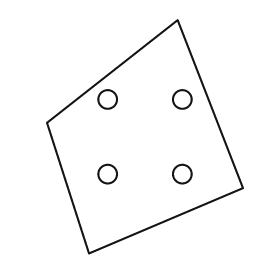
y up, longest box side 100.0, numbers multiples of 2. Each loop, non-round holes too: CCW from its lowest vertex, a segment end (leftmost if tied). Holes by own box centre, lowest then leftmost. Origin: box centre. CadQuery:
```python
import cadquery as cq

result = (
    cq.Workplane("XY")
    .moveTo(-24.0, -50.0)
    .lineTo(42.0, -22.0)
    .lineTo(14.0, 50.0)
    .lineTo(-42.0, 6.0)
    .close()
    .moveTo(-16.0, -16.0)
    .circle(4.0)
    .moveTo(16.0, -16.0)
    .circle(4.0)
    .moveTo(-16.0, 16.0)
    .circle(4.0)
    .moveTo(16.0, 16.0)
    .circle(4.0)
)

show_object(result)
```